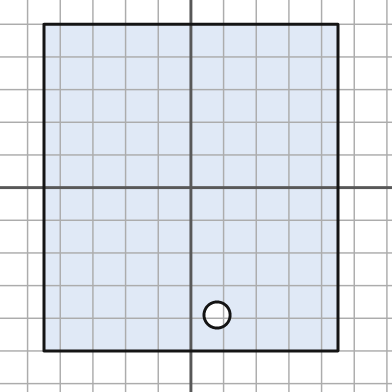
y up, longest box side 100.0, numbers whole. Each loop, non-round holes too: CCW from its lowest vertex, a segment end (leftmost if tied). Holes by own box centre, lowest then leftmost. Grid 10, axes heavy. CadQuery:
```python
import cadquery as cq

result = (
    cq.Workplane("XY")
    .moveTo(-45.0, -50.0)
    .lineTo(45.0, -50.0)
    .lineTo(45.0, 50.0)
    .lineTo(-45.0, 50.0)
    .close()
    .moveTo(8.0, -39.0)
    .circle(4.0)
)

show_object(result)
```